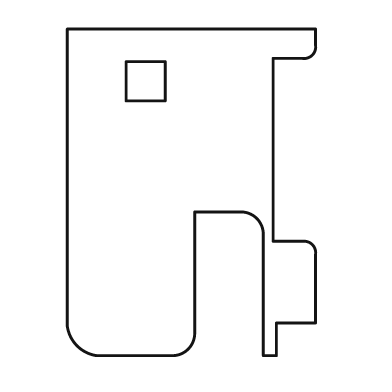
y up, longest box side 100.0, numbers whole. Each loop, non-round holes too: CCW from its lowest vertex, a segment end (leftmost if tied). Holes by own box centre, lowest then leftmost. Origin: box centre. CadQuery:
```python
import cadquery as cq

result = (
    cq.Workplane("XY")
    .moveTo(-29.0, -50.0)
    .lineTo(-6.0, -50.0)
    .threePointArc((-1.0, -48.0), (1.0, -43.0))
    .lineTo(1.0, -6.0)
    .lineTo(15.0, -6.0)
    .threePointArc((20.0, -8.0), (22.0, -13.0))
    .lineTo(22.0, -50.0)
    .lineTo(26.0, -50.0)
    .lineTo(26.0, -40.0)
    .lineTo(38.0, -40.0)
    .lineTo(38.0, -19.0)
    .threePointArc((37.0, -16.0), (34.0, -15.0))
    .lineTo(25.0, -15.0)
    .lineTo(25.0, 41.0)
    .lineTo(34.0, 41.0)
    .threePointArc((37.0, 42.0), (38.0, 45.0))
    .lineTo(38.0, 50.0)
    .lineTo(-38.0, 50.0)
    .lineTo(-38.0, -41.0)
    .threePointArc((-35.0, -47.0), (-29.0, -50.0))
    .close()
    .moveTo(-20.0, 28.0)
    .lineTo(-8.0, 28.0)
    .lineTo(-8.0, 40.0)
    .lineTo(-20.0, 40.0)
    .close()
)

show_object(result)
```